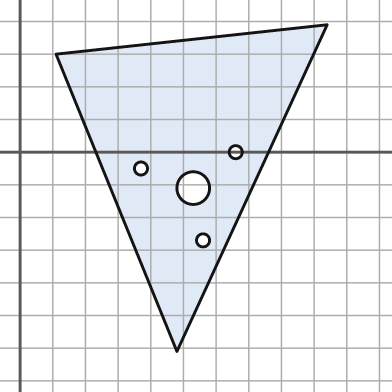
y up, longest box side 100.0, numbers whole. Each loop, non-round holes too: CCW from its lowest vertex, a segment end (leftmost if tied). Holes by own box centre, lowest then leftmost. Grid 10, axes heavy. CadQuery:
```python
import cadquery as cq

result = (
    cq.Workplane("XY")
    .moveTo(48.0, -61.0)
    .lineTo(94.0, 39.0)
    .lineTo(11.0, 30.0)
    .close()
    .moveTo(56.0, -27.0)
    .circle(2.0)
    .moveTo(53.0, -11.0)
    .circle(5.0)
    .moveTo(37.0, -5.0)
    .circle(2.0)
    .moveTo(66.0, 0.0)
    .circle(2.0)
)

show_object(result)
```